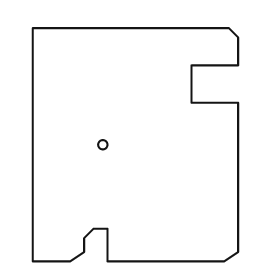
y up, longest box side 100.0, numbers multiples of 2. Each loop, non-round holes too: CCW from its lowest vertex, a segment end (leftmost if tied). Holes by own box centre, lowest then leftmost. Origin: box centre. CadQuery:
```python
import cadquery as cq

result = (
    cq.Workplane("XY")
    .moveTo(-44.0, -50.0)
    .lineTo(-28.0, -50.0)
    .lineTo(-22.0, -46.0)
    .lineTo(-22.0, -40.0)
    .lineTo(-18.0, -36.0)
    .lineTo(-12.0, -36.0)
    .lineTo(-12.0, -50.0)
    .lineTo(38.0, -50.0)
    .lineTo(44.0, -46.0)
    .lineTo(44.0, 18.0)
    .lineTo(24.0, 18.0)
    .lineTo(24.0, 34.0)
    .lineTo(44.0, 34.0)
    .lineTo(44.0, 46.0)
    .lineTo(40.0, 50.0)
    .lineTo(-44.0, 50.0)
    .close()
    .moveTo(-14.0, 0.0)
    .circle(2.0)
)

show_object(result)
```